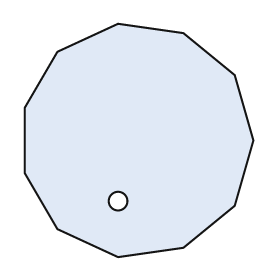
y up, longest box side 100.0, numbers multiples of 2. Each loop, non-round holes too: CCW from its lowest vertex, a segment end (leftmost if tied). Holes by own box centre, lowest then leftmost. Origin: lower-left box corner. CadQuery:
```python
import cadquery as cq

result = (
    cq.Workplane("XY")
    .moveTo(40.0, 0.0)
    .lineTo(68.0, 4.0)
    .lineTo(90.0, 22.0)
    .lineTo(98.0, 50.0)
    .lineTo(90.0, 78.0)
    .lineTo(68.0, 96.0)
    .lineTo(40.0, 100.0)
    .lineTo(14.0, 88.0)
    .lineTo(0.0, 64.0)
    .lineTo(0.0, 36.0)
    .lineTo(14.0, 12.0)
    .close()
    .moveTo(40.0, 24.0)
    .circle(4.0)
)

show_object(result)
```